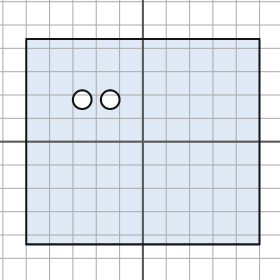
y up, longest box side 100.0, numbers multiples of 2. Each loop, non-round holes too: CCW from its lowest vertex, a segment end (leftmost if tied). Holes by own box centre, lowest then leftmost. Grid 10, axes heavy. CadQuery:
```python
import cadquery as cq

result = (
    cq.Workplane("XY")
    .moveTo(-50.0, -44.0)
    .lineTo(50.0, -44.0)
    .lineTo(50.0, 44.0)
    .lineTo(-50.0, 44.0)
    .close()
    .moveTo(-26.0, 18.0)
    .circle(4.0)
    .moveTo(-14.0, 18.0)
    .circle(4.0)
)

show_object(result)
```